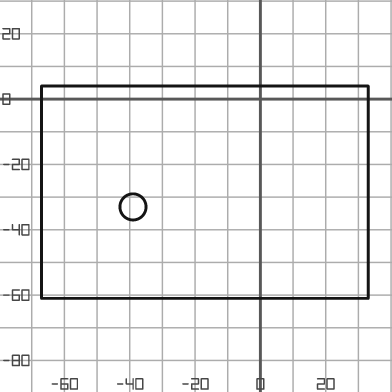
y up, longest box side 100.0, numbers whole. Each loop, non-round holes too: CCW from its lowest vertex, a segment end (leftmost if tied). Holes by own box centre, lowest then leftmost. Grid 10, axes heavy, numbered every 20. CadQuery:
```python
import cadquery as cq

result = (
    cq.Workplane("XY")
    .moveTo(-67.0, -61.0)
    .lineTo(33.0, -61.0)
    .lineTo(33.0, 4.0)
    .lineTo(-67.0, 4.0)
    .close()
    .moveTo(-39.0, -33.0)
    .circle(4.0)
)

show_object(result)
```